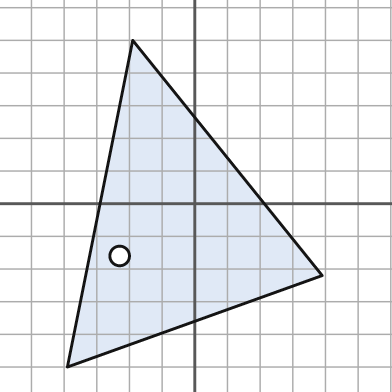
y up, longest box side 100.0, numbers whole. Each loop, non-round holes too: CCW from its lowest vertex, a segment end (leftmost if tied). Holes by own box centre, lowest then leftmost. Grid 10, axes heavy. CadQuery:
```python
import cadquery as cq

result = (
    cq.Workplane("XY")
    .moveTo(-39.0, -50.0)
    .lineTo(39.0, -22.0)
    .lineTo(-19.0, 50.0)
    .close()
    .moveTo(-23.0, -16.0)
    .circle(3.0)
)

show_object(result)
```